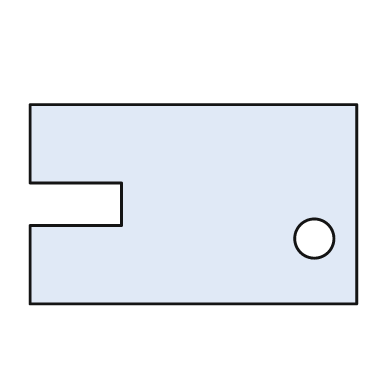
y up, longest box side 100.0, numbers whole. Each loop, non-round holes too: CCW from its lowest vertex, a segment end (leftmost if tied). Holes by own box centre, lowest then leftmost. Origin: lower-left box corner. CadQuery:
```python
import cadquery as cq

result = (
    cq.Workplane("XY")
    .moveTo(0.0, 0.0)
    .lineTo(100.0, 0.0)
    .lineTo(100.0, 61.0)
    .lineTo(0.0, 61.0)
    .lineTo(0.0, 37.0)
    .lineTo(28.0, 37.0)
    .lineTo(28.0, 24.0)
    .lineTo(0.0, 24.0)
    .close()
    .moveTo(87.0, 20.0)
    .circle(6.0)
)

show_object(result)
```